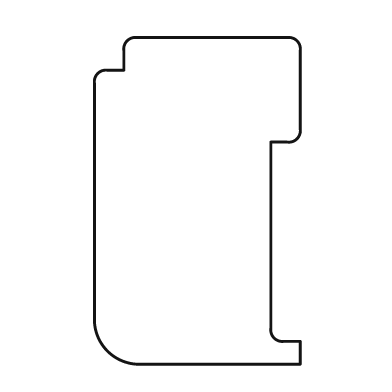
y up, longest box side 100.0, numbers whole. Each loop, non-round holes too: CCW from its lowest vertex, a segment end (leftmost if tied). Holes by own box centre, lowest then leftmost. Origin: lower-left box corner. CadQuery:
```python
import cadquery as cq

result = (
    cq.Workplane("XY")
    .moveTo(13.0, 0.0)
    .lineTo(63.0, 0.0)
    .lineTo(63.0, 7.0)
    .lineTo(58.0, 7.0)
    .threePointArc((55.0, 8.0), (54.0, 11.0))
    .lineTo(54.0, 68.0)
    .lineTo(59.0, 68.0)
    .threePointArc((62.0, 69.0), (63.0, 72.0))
    .lineTo(63.0, 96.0)
    .threePointArc((62.0, 99.0), (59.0, 100.0))
    .lineTo(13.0, 100.0)
    .threePointArc((10.0, 99.0), (9.0, 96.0))
    .lineTo(9.0, 90.0)
    .lineTo(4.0, 90.0)
    .threePointArc((1.0, 89.0), (0.0, 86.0))
    .lineTo(0.0, 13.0)
    .threePointArc((4.0, 4.0), (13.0, 0.0))
    .close()
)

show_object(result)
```